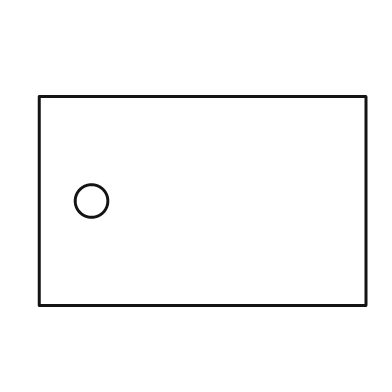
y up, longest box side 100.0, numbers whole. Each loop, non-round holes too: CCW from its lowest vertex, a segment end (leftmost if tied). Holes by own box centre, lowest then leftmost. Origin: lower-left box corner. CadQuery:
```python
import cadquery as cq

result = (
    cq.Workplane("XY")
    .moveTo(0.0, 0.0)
    .lineTo(100.0, 0.0)
    .lineTo(100.0, 64.0)
    .lineTo(0.0, 64.0)
    .close()
    .moveTo(16.0, 32.0)
    .circle(5.0)
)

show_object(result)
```